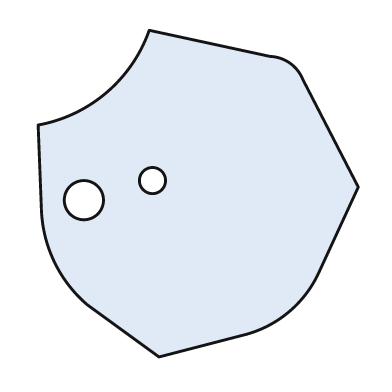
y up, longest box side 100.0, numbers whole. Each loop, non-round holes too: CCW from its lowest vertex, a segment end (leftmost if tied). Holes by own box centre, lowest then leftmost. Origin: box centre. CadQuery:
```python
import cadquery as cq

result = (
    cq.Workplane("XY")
    .moveTo(-12.0, -50.0)
    .lineTo(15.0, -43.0)
    .threePointArc((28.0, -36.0), (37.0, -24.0))
    .lineTo(49.0, 2.0)
    .lineTo(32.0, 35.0)
    .threePointArc((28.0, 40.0), (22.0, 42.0))
    .lineTo(-15.0, 50.0)
    .threePointArc((-28.0, 31.0), (-49.0, 21.0))
    .lineTo(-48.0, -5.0)
    .threePointArc((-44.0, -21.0), (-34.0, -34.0))
    .close()
    .moveTo(-35.0, -2.0)
    .circle(6.0)
    .moveTo(-14.0, 4.0)
    .circle(4.0)
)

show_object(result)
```